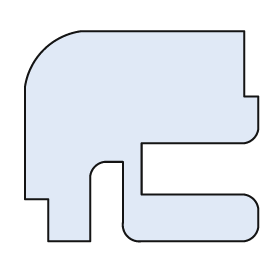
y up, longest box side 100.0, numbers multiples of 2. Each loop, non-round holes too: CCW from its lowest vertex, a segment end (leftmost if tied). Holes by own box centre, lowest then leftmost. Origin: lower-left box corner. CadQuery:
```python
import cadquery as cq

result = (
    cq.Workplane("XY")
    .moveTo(10.0, 0.0)
    .lineTo(28.0, 0.0)
    .lineTo(28.0, 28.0)
    .threePointArc((30.0, 32.0), (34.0, 34.0))
    .lineTo(42.0, 34.0)
    .lineTo(42.0, 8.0)
    .threePointArc((44.0, 2.0), (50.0, 0.0))
    .lineTo(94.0, 0.0)
    .threePointArc((98.0, 2.0), (100.0, 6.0))
    .lineTo(100.0, 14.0)
    .threePointArc((98.0, 18.0), (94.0, 20.0))
    .lineTo(50.0, 20.0)
    .lineTo(50.0, 42.0)
    .lineTo(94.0, 42.0)
    .threePointArc((98.0, 44.0), (100.0, 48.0))
    .lineTo(100.0, 62.0)
    .lineTo(94.0, 62.0)
    .lineTo(94.0, 90.0)
    .lineTo(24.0, 90.0)
    .threePointArc((8.0, 82.0), (0.0, 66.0))
    .lineTo(0.0, 18.0)
    .lineTo(10.0, 18.0)
    .close()
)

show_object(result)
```